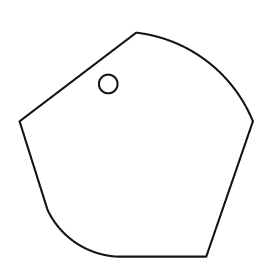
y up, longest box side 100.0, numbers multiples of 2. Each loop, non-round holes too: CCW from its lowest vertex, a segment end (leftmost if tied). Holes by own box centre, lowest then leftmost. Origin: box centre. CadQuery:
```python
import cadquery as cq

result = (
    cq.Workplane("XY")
    .moveTo(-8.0, -48.0)
    .lineTo(30.0, -48.0)
    .lineTo(50.0, 10.0)
    .threePointArc((30.0, 36.0), (0.0, 48.0))
    .lineTo(-50.0, 10.0)
    .lineTo(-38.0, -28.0)
    .threePointArc((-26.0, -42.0), (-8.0, -48.0))
    .close()
    .moveTo(-12.0, 26.0)
    .circle(4.0)
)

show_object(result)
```